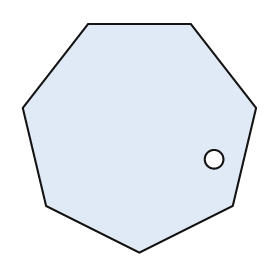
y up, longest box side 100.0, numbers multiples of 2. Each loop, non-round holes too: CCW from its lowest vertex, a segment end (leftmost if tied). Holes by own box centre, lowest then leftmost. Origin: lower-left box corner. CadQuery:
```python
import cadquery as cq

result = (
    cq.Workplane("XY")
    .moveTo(50.0, 0.0)
    .lineTo(90.0, 20.0)
    .lineTo(100.0, 62.0)
    .lineTo(72.0, 98.0)
    .lineTo(28.0, 98.0)
    .lineTo(0.0, 62.0)
    .lineTo(10.0, 20.0)
    .close()
    .moveTo(82.0, 40.0)
    .circle(4.0)
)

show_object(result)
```